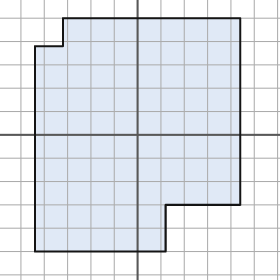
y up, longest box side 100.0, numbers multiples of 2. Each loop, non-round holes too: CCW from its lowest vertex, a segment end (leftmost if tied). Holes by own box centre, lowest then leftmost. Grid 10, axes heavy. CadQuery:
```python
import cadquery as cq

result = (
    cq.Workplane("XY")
    .moveTo(-44.0, -50.0)
    .lineTo(12.0, -50.0)
    .lineTo(12.0, -30.0)
    .lineTo(44.0, -30.0)
    .lineTo(44.0, 50.0)
    .lineTo(-32.0, 50.0)
    .lineTo(-32.0, 38.0)
    .lineTo(-44.0, 38.0)
    .close()
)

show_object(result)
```